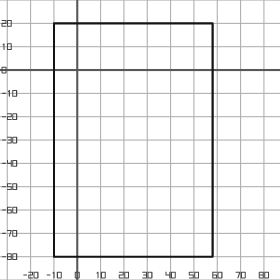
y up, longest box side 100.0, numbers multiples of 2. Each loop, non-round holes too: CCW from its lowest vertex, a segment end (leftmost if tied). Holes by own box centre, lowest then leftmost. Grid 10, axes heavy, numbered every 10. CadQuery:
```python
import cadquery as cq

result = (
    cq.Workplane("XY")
    .moveTo(-10.0, -80.0)
    .lineTo(58.0, -80.0)
    .lineTo(58.0, 20.0)
    .lineTo(-10.0, 20.0)
    .close()
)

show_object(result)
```